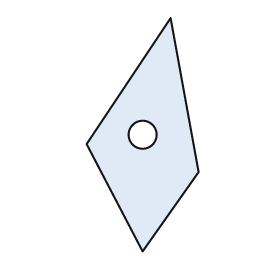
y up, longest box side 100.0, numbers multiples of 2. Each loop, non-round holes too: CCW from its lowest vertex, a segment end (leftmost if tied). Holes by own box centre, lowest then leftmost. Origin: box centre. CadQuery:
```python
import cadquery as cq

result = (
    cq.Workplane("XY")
    .moveTo(0.0, -50.0)
    .lineTo(24.0, -16.0)
    .lineTo(12.0, 50.0)
    .lineTo(-24.0, -4.0)
    .close()
    .moveTo(0.0, 0.0)
    .circle(6.0)
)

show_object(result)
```